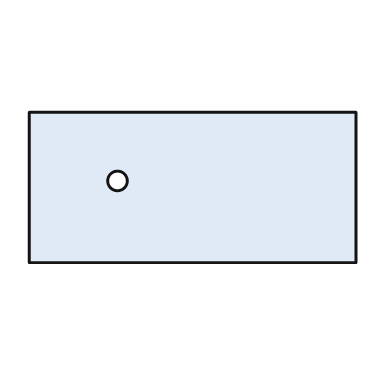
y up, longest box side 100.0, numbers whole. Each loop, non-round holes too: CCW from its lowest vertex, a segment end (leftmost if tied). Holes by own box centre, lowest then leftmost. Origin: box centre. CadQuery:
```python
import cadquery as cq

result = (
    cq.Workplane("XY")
    .moveTo(-50.0, -23.0)
    .lineTo(50.0, -23.0)
    .lineTo(50.0, 23.0)
    .lineTo(-50.0, 23.0)
    .close()
    .moveTo(-23.0, 2.0)
    .circle(3.0)
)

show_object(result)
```